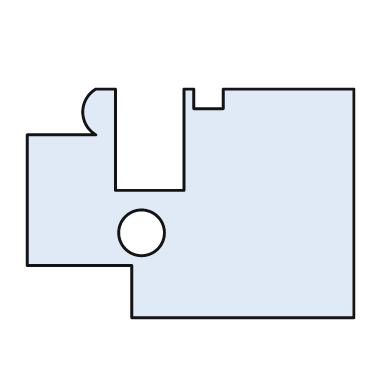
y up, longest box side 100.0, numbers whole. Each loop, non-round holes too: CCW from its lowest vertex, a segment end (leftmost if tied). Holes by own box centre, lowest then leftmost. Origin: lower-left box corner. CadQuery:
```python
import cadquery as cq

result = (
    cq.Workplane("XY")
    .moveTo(32.0, 0.0)
    .lineTo(100.0, 0.0)
    .lineTo(100.0, 70.0)
    .lineTo(60.0, 70.0)
    .lineTo(60.0, 64.0)
    .lineTo(51.0, 64.0)
    .lineTo(51.0, 70.0)
    .lineTo(48.0, 70.0)
    .lineTo(48.0, 39.0)
    .lineTo(27.0, 39.0)
    .lineTo(27.0, 70.0)
    .lineTo(21.0, 70.0)
    .threePointArc((17.0, 63.0), (21.0, 56.0))
    .lineTo(0.0, 56.0)
    .lineTo(0.0, 16.0)
    .lineTo(32.0, 16.0)
    .close()
    .moveTo(35.0, 26.0)
    .circle(7.0)
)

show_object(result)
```